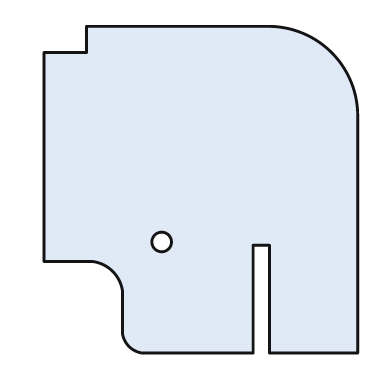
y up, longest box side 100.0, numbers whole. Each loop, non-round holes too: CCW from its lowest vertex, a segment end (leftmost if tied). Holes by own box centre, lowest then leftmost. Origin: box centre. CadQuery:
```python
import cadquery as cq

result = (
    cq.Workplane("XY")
    .moveTo(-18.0, -50.0)
    .lineTo(16.0, -50.0)
    .lineTo(16.0, -17.0)
    .lineTo(21.0, -17.0)
    .lineTo(21.0, -50.0)
    .lineTo(48.0, -50.0)
    .lineTo(48.0, 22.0)
    .threePointArc((40.0, 42.0), (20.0, 50.0))
    .lineTo(-35.0, 50.0)
    .lineTo(-35.0, 42.0)
    .lineTo(-48.0, 42.0)
    .lineTo(-48.0, -22.0)
    .lineTo(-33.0, -22.0)
    .threePointArc((-27.0, -25.0), (-24.0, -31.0))
    .lineTo(-24.0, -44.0)
    .threePointArc((-22.0, -48.0), (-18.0, -50.0))
    .close()
    .moveTo(-12.0, -16.0)
    .circle(3.0)
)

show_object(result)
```